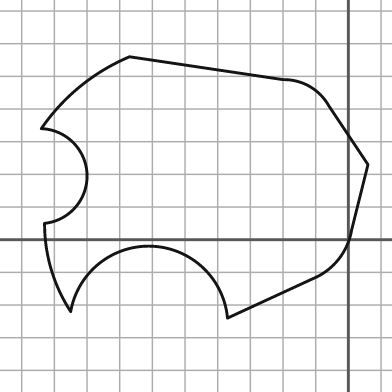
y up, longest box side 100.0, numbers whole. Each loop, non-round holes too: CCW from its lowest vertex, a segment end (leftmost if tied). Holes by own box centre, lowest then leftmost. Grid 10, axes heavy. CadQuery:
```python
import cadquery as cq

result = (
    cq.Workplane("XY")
    .moveTo(-37.0, -24.0)
    .lineTo(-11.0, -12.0)
    .threePointArc((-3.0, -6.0), (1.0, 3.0))
    .lineTo(6.0, 23.0)
    .lineTo(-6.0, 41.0)
    .threePointArc((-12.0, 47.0), (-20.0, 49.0))
    .lineTo(-67.0, 56.0)
    .threePointArc((-82.0, 47.0), (-94.0, 34.0))
    .threePointArc((-80.0, 20.0), (-93.0, 5.0))
    .threePointArc((-91.0, -9.0), (-85.0, -22.0))
    .threePointArc((-60.0, -2.0), (-37.0, -24.0))
    .close()
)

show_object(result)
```